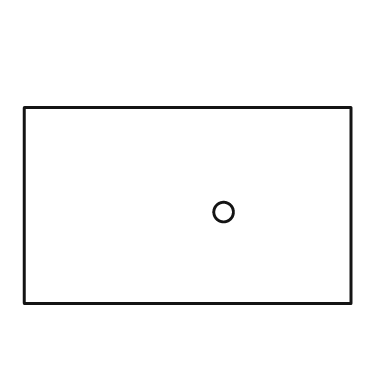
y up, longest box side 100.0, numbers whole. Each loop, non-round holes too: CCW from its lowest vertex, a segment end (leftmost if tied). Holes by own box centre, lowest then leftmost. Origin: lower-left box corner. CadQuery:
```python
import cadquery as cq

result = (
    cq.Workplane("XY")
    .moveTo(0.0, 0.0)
    .lineTo(100.0, 0.0)
    .lineTo(100.0, 60.0)
    .lineTo(0.0, 60.0)
    .close()
    .moveTo(61.0, 28.0)
    .circle(3.0)
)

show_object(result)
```